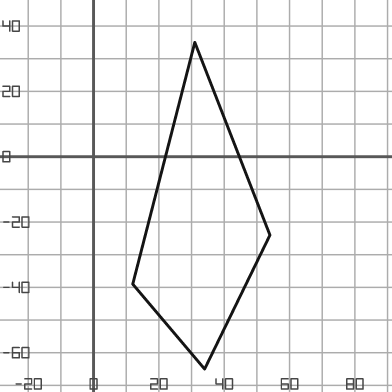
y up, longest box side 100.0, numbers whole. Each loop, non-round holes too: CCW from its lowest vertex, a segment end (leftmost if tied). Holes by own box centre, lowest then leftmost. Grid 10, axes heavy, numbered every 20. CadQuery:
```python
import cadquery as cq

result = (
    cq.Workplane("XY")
    .moveTo(34.0, -65.0)
    .lineTo(54.0, -24.0)
    .lineTo(31.0, 35.0)
    .lineTo(12.0, -39.0)
    .close()
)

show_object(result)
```